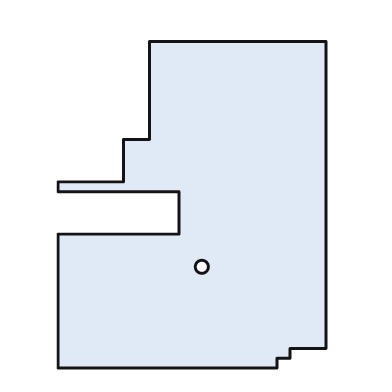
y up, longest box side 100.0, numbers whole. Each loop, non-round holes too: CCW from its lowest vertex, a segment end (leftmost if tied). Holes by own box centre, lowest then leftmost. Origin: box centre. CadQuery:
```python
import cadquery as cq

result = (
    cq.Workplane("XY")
    .moveTo(-41.0, -50.0)
    .lineTo(26.0, -50.0)
    .lineTo(26.0, -47.0)
    .lineTo(30.0, -47.0)
    .lineTo(30.0, -44.0)
    .lineTo(41.0, -44.0)
    .lineTo(41.0, 50.0)
    .lineTo(-13.0, 50.0)
    .lineTo(-13.0, 20.0)
    .lineTo(-21.0, 20.0)
    .lineTo(-21.0, 7.0)
    .lineTo(-41.0, 7.0)
    .lineTo(-41.0, 4.0)
    .lineTo(-4.0, 4.0)
    .lineTo(-4.0, -9.0)
    .lineTo(-41.0, -9.0)
    .close()
    .moveTo(3.0, -19.0)
    .circle(2.0)
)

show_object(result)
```